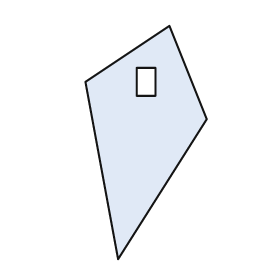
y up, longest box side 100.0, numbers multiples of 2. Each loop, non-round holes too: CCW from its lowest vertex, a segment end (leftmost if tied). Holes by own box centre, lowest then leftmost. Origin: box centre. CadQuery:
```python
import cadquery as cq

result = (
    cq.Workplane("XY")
    .moveTo(-12.0, -50.0)
    .lineTo(26.0, 10.0)
    .lineTo(10.0, 50.0)
    .lineTo(-26.0, 26.0)
    .close()
    .moveTo(-4.0, 20.0)
    .lineTo(4.0, 20.0)
    .lineTo(4.0, 32.0)
    .lineTo(-4.0, 32.0)
    .close()
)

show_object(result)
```